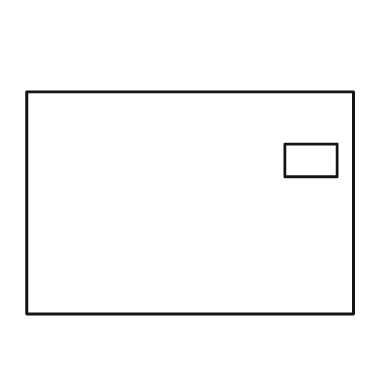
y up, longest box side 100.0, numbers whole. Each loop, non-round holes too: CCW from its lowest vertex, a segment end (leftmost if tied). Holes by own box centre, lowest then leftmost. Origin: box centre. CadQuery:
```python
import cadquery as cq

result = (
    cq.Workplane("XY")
    .moveTo(-50.0, -34.0)
    .lineTo(50.0, -34.0)
    .lineTo(50.0, 34.0)
    .lineTo(-50.0, 34.0)
    .close()
    .moveTo(29.0, 8.0)
    .lineTo(45.0, 8.0)
    .lineTo(45.0, 18.0)
    .lineTo(29.0, 18.0)
    .close()
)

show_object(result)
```